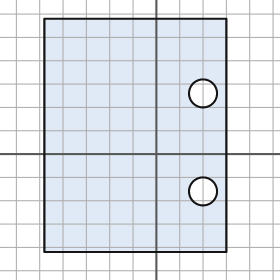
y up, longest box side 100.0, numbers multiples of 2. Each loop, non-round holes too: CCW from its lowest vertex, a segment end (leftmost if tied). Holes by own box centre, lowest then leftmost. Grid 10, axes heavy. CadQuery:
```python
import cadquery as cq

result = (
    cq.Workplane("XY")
    .moveTo(-48.0, -42.0)
    .lineTo(30.0, -42.0)
    .lineTo(30.0, 58.0)
    .lineTo(-48.0, 58.0)
    .close()
    .moveTo(20.0, -16.0)
    .circle(6.0)
    .moveTo(20.0, 26.0)
    .circle(6.0)
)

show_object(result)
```